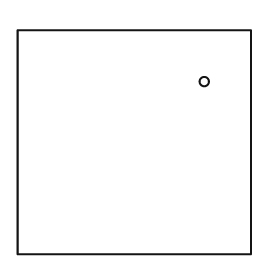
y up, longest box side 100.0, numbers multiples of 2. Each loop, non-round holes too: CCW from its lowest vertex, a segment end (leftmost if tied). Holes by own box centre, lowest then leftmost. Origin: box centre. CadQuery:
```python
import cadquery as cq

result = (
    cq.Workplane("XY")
    .moveTo(-50.0, -48.0)
    .lineTo(50.0, -48.0)
    .lineTo(50.0, 48.0)
    .lineTo(-50.0, 48.0)
    .close()
    .moveTo(30.0, 26.0)
    .circle(2.0)
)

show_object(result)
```